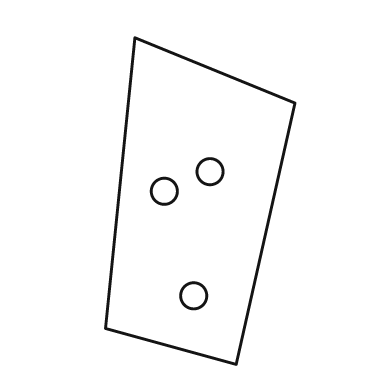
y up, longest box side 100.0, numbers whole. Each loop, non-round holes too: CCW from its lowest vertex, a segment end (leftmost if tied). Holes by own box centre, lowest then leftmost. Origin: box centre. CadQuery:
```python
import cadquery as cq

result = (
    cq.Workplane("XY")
    .moveTo(11.0, -50.0)
    .lineTo(29.0, 30.0)
    .lineTo(-20.0, 50.0)
    .lineTo(-29.0, -39.0)
    .close()
    .moveTo(-2.0, -29.0)
    .circle(4.0)
    .moveTo(-11.0, 3.0)
    .circle(4.0)
    .moveTo(3.0, 9.0)
    .circle(4.0)
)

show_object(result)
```